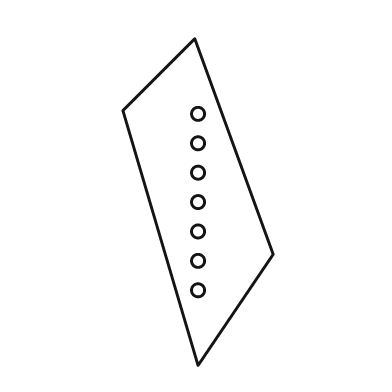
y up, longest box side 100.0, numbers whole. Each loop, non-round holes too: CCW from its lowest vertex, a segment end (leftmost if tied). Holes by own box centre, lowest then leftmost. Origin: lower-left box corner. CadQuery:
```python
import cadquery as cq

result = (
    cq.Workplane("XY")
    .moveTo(23.0, 0.0)
    .lineTo(46.0, 34.0)
    .lineTo(22.0, 100.0)
    .lineTo(0.0, 78.0)
    .close()
    .moveTo(23.0, 23.0)
    .circle(2.0)
    .moveTo(23.0, 32.0)
    .circle(2.0)
    .moveTo(23.0, 41.0)
    .circle(2.0)
    .moveTo(23.0, 50.0)
    .circle(2.0)
    .moveTo(23.0, 59.0)
    .circle(2.0)
    .moveTo(23.0, 68.0)
    .circle(2.0)
    .moveTo(23.0, 77.0)
    .circle(2.0)
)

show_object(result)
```